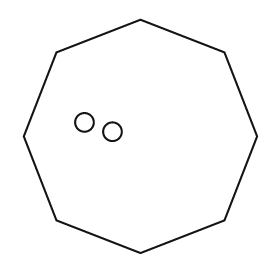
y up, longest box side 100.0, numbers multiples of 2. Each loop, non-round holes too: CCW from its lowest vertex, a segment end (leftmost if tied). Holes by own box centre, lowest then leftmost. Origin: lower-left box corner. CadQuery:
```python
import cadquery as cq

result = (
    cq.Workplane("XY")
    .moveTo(50.0, 0.0)
    .lineTo(86.0, 14.0)
    .lineTo(100.0, 50.0)
    .lineTo(86.0, 86.0)
    .lineTo(50.0, 100.0)
    .lineTo(14.0, 86.0)
    .lineTo(0.0, 50.0)
    .lineTo(14.0, 14.0)
    .close()
    .moveTo(38.0, 52.0)
    .circle(4.0)
    .moveTo(26.0, 56.0)
    .circle(4.0)
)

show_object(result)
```